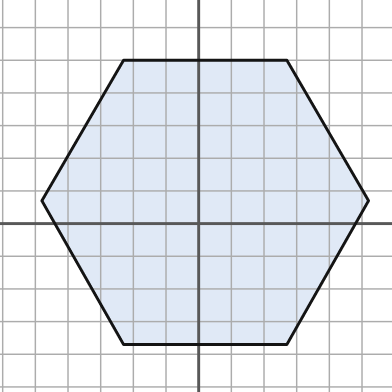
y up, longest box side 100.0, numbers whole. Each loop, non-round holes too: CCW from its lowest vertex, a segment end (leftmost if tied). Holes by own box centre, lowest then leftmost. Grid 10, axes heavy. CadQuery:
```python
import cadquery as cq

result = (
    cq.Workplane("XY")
    .moveTo(-23.0, -37.0)
    .lineTo(27.0, -37.0)
    .lineTo(52.0, 7.0)
    .lineTo(27.0, 50.0)
    .lineTo(-23.0, 50.0)
    .lineTo(-48.0, 7.0)
    .close()
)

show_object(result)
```